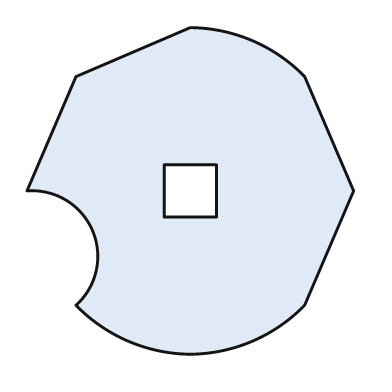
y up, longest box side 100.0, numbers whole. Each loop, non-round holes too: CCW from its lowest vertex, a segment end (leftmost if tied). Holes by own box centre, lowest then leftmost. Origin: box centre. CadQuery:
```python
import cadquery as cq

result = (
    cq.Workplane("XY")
    .moveTo(0.0, -50.0)
    .threePointArc((19.0, -46.0), (35.0, -35.0))
    .lineTo(50.0, 0.0)
    .lineTo(35.0, 35.0)
    .threePointArc((19.0, 46.0), (0.0, 50.0))
    .lineTo(-35.0, 35.0)
    .lineTo(-50.0, 0.0)
    .threePointArc((-30.0, -12.0), (-35.0, -35.0))
    .threePointArc((-19.0, -46.0), (0.0, -50.0))
    .close()
    .moveTo(-8.0, -8.0)
    .lineTo(8.0, -8.0)
    .lineTo(8.0, 8.0)
    .lineTo(-8.0, 8.0)
    .close()
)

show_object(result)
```